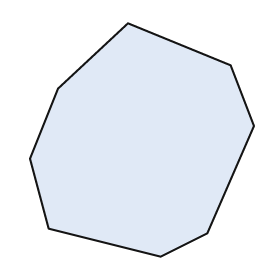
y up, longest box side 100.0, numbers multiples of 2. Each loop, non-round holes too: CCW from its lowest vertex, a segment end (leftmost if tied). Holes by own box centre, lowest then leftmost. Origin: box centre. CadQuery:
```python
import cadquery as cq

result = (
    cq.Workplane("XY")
    .moveTo(8.0, -50.0)
    .lineTo(28.0, -40.0)
    .lineTo(48.0, 6.0)
    .lineTo(38.0, 32.0)
    .lineTo(-6.0, 50.0)
    .lineTo(-36.0, 22.0)
    .lineTo(-48.0, -8.0)
    .lineTo(-40.0, -38.0)
    .close()
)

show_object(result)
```